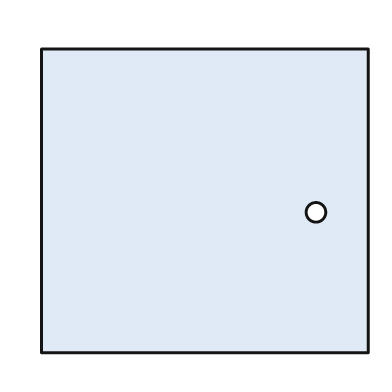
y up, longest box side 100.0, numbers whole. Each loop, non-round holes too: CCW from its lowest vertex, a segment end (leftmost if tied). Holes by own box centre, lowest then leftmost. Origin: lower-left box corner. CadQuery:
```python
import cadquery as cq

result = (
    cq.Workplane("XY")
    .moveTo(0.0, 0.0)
    .lineTo(100.0, 0.0)
    .lineTo(100.0, 93.0)
    .lineTo(0.0, 93.0)
    .close()
    .moveTo(84.0, 43.0)
    .circle(3.0)
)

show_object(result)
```